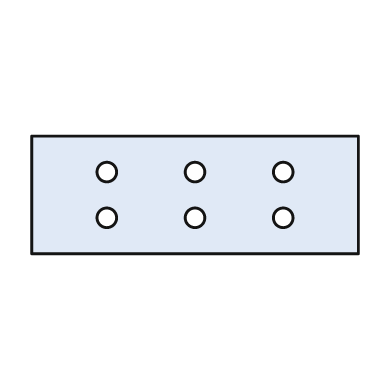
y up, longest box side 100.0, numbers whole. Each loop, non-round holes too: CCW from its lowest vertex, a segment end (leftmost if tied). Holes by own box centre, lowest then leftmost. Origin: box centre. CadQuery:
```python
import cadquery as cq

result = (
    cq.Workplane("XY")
    .moveTo(-50.0, -18.0)
    .lineTo(50.0, -18.0)
    .lineTo(50.0, 18.0)
    .lineTo(-50.0, 18.0)
    .close()
    .moveTo(-27.0, -7.0)
    .circle(3.0)
    .moveTo(0.0, -7.0)
    .circle(3.0)
    .moveTo(27.0, -7.0)
    .circle(3.0)
    .moveTo(-27.0, 7.0)
    .circle(3.0)
    .moveTo(0.0, 7.0)
    .circle(3.0)
    .moveTo(27.0, 7.0)
    .circle(3.0)
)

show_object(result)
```